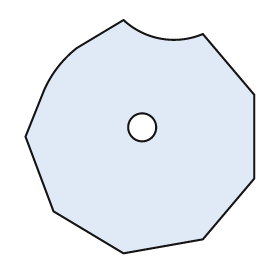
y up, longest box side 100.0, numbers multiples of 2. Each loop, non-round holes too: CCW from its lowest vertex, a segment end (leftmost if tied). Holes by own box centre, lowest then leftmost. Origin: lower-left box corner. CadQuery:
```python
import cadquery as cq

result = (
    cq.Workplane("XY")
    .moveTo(42.0, 0.0)
    .lineTo(76.0, 6.0)
    .lineTo(98.0, 32.0)
    .lineTo(98.0, 68.0)
    .lineTo(76.0, 94.0)
    .threePointArc((58.0, 92.0), (42.0, 100.0))
    .lineTo(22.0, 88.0)
    .threePointArc((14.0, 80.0), (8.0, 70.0))
    .lineTo(0.0, 50.0)
    .lineTo(12.0, 18.0)
    .close()
    .moveTo(50.0, 54.0)
    .circle(6.0)
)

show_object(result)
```